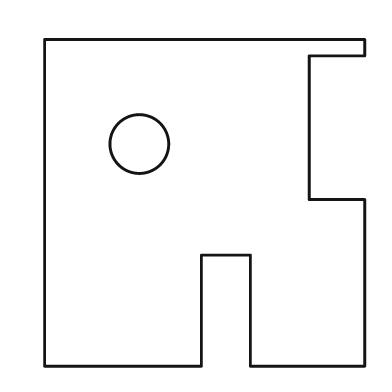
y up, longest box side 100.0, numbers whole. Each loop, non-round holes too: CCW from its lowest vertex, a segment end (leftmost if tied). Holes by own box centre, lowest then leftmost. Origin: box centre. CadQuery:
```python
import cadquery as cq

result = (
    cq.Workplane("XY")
    .moveTo(-49.0, -50.0)
    .lineTo(-1.0, -50.0)
    .lineTo(-1.0, -16.0)
    .lineTo(14.0, -16.0)
    .lineTo(14.0, -50.0)
    .lineTo(49.0, -50.0)
    .lineTo(49.0, 1.0)
    .lineTo(32.0, 1.0)
    .lineTo(32.0, 45.0)
    .lineTo(49.0, 45.0)
    .lineTo(49.0, 50.0)
    .lineTo(-49.0, 50.0)
    .close()
    .moveTo(-20.0, 18.0)
    .circle(9.0)
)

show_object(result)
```